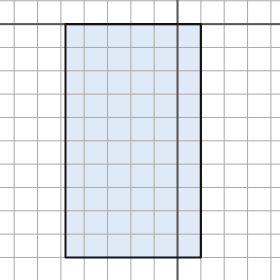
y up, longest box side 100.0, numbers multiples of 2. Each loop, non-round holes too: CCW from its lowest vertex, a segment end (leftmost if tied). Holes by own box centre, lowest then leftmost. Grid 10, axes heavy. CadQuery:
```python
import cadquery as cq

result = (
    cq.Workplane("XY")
    .moveTo(-48.0, -100.0)
    .lineTo(10.0, -100.0)
    .lineTo(10.0, 0.0)
    .lineTo(-48.0, 0.0)
    .close()
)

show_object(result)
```